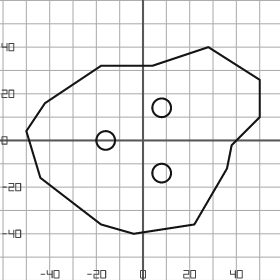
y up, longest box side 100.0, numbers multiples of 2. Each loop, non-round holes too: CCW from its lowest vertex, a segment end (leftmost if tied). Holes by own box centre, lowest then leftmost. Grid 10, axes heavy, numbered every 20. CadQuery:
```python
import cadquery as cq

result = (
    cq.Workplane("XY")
    .moveTo(-4.0, -40.0)
    .lineTo(22.0, -36.0)
    .lineTo(36.0, -12.0)
    .lineTo(38.0, -2.0)
    .lineTo(50.0, 10.0)
    .lineTo(50.0, 26.0)
    .lineTo(28.0, 40.0)
    .lineTo(4.0, 32.0)
    .lineTo(-18.0, 32.0)
    .lineTo(-42.0, 16.0)
    .lineTo(-50.0, 4.0)
    .lineTo(-44.0, -16.0)
    .lineTo(-18.0, -36.0)
    .close()
    .moveTo(8.0, -14.0)
    .circle(4.0)
    .moveTo(-16.0, 0.0)
    .circle(4.0)
    .moveTo(8.0, 14.0)
    .circle(4.0)
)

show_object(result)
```